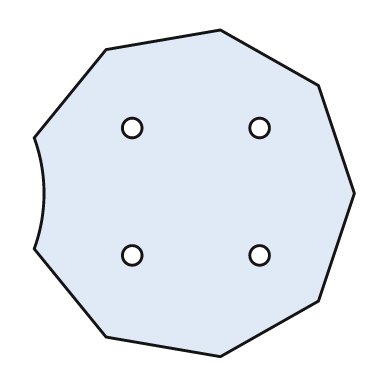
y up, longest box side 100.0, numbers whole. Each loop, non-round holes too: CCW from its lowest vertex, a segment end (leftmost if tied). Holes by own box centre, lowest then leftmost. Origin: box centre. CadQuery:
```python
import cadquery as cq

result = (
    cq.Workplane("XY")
    .moveTo(8.0, -50.0)
    .lineTo(38.0, -33.0)
    .lineTo(49.0, 0.0)
    .lineTo(38.0, 33.0)
    .lineTo(8.0, 50.0)
    .lineTo(-27.0, 44.0)
    .lineTo(-49.0, 17.0)
    .threePointArc((-46.0, 0.0), (-49.0, -17.0))
    .lineTo(-27.0, -44.0)
    .close()
    .moveTo(-19.0, -19.0)
    .circle(3.0)
    .moveTo(20.0, -19.0)
    .circle(3.0)
    .moveTo(-19.0, 20.0)
    .circle(3.0)
    .moveTo(20.0, 20.0)
    .circle(3.0)
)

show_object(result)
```